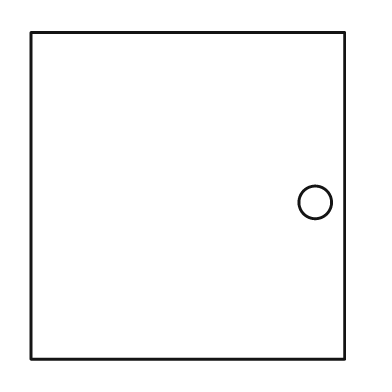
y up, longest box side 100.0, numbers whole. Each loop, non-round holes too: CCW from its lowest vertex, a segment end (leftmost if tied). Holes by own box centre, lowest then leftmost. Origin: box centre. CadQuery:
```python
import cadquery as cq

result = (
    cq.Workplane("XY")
    .moveTo(-48.0, -50.0)
    .lineTo(48.0, -50.0)
    .lineTo(48.0, 50.0)
    .lineTo(-48.0, 50.0)
    .close()
    .moveTo(39.0, -2.0)
    .circle(5.0)
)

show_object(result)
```